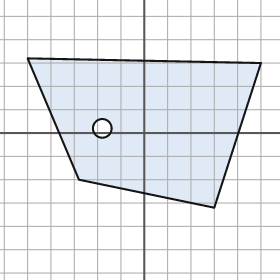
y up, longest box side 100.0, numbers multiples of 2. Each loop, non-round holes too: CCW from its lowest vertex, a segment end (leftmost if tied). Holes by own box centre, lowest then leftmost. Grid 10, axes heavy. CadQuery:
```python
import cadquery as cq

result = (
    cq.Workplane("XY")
    .moveTo(30.0, -32.0)
    .lineTo(50.0, 30.0)
    .lineTo(-50.0, 32.0)
    .lineTo(-28.0, -20.0)
    .close()
    .moveTo(-18.0, 2.0)
    .circle(4.0)
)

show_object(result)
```